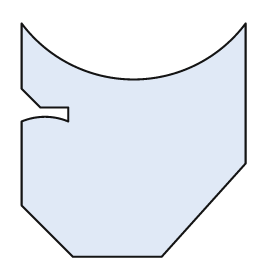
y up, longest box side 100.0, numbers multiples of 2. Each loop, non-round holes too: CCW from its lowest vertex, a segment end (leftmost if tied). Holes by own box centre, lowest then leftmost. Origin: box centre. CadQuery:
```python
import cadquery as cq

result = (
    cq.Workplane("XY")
    .moveTo(-26.0, -50.0)
    .lineTo(12.0, -50.0)
    .lineTo(48.0, -10.0)
    .lineTo(48.0, 50.0)
    .threePointArc((0.0, 26.0), (-48.0, 50.0))
    .lineTo(-48.0, 22.0)
    .lineTo(-40.0, 14.0)
    .lineTo(-28.0, 14.0)
    .lineTo(-28.0, 8.0)
    .threePointArc((-38.0, 10.0), (-48.0, 8.0))
    .lineTo(-48.0, -28.0)
    .close()
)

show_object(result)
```